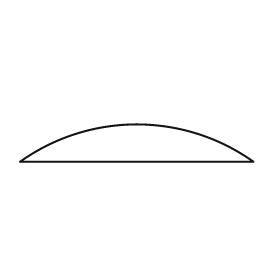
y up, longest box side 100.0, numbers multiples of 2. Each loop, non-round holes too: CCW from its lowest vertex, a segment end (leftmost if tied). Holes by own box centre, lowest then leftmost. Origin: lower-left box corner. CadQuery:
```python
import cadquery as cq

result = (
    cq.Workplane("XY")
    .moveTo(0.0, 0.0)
    .lineTo(100.0, 0.0)
    .threePointArc((50.0, 16.0), (0.0, 0.0))
    .close()
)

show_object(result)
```